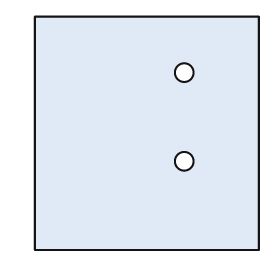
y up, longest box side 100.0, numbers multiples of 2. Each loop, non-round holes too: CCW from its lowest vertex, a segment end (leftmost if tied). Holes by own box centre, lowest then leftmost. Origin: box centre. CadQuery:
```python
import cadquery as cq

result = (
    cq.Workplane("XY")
    .moveTo(-48.0, -50.0)
    .lineTo(48.0, -50.0)
    .lineTo(48.0, 50.0)
    .lineTo(-48.0, 50.0)
    .close()
    .moveTo(16.0, -12.0)
    .circle(4.0)
    .moveTo(16.0, 26.0)
    .circle(4.0)
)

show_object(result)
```